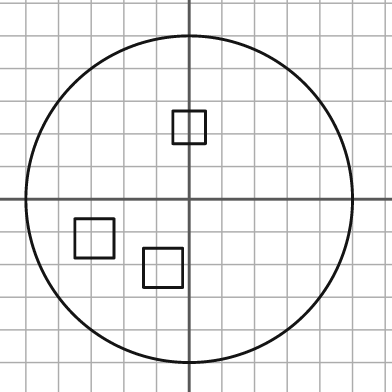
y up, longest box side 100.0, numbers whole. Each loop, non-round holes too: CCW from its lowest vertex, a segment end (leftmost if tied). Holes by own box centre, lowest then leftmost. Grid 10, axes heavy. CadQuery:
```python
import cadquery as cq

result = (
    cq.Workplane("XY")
    .moveTo(0.0, 0.0)
    .circle(50.0)
    .moveTo(-14.0, -27.0)
    .lineTo(-2.0, -27.0)
    .lineTo(-2.0, -15.0)
    .lineTo(-14.0, -15.0)
    .close()
    .moveTo(-35.0, -18.0)
    .lineTo(-23.0, -18.0)
    .lineTo(-23.0, -6.0)
    .lineTo(-35.0, -6.0)
    .close()
    .moveTo(-5.0, 17.0)
    .lineTo(5.0, 17.0)
    .lineTo(5.0, 27.0)
    .lineTo(-5.0, 27.0)
    .close()
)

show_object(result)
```